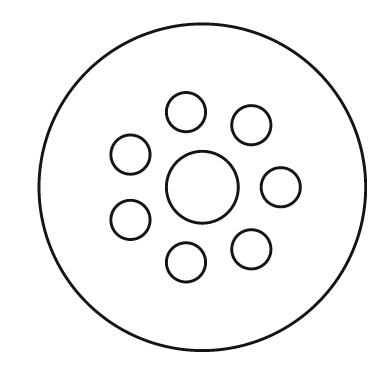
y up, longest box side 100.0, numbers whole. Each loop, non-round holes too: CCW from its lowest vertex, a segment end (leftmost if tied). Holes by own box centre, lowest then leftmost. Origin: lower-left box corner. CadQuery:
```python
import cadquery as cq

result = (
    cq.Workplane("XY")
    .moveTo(50.0, 50.0)
    .circle(50.0)
    .moveTo(45.0, 27.0)
    .circle(6.0)
    .moveTo(65.0, 31.0)
    .circle(6.0)
    .moveTo(28.0, 40.0)
    .circle(6.0)
    .moveTo(50.0, 50.0)
    .circle(11.0)
    .moveTo(74.0, 50.0)
    .circle(6.0)
    .moveTo(28.0, 60.0)
    .circle(6.0)
    .moveTo(65.0, 69.0)
    .circle(6.0)
    .moveTo(45.0, 73.0)
    .circle(6.0)
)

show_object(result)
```